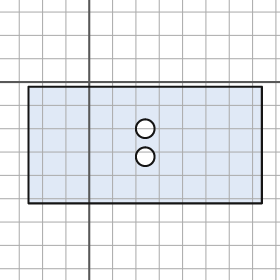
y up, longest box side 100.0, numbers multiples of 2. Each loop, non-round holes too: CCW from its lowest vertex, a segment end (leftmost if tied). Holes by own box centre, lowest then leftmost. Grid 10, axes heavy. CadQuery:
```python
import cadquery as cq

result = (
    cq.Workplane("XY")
    .moveTo(-26.0, -52.0)
    .lineTo(74.0, -52.0)
    .lineTo(74.0, -2.0)
    .lineTo(-26.0, -2.0)
    .close()
    .moveTo(24.0, -32.0)
    .circle(4.0)
    .moveTo(24.0, -20.0)
    .circle(4.0)
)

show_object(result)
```